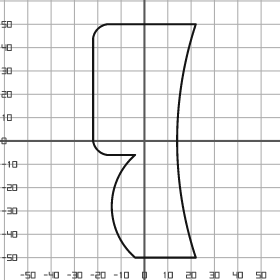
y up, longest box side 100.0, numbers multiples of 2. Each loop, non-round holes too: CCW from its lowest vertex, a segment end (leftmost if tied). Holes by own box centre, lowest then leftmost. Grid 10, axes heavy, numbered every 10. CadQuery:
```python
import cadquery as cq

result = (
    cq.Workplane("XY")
    .moveTo(-4.0, -50.0)
    .lineTo(22.0, -50.0)
    .threePointArc((14.0, 0.0), (22.0, 50.0))
    .lineTo(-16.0, 50.0)
    .threePointArc((-20.0, 48.0), (-22.0, 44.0))
    .lineTo(-22.0, 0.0)
    .threePointArc((-20.0, -4.0), (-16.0, -6.0))
    .lineTo(-4.0, -6.0)
    .threePointArc((-14.0, -28.0), (-4.0, -50.0))
    .close()
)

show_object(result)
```